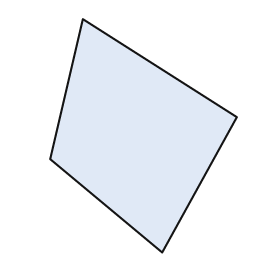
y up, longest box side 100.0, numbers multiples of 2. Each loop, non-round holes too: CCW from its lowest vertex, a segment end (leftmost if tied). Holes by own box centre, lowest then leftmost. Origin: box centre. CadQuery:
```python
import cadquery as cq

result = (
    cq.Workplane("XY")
    .moveTo(8.0, -50.0)
    .lineTo(40.0, 8.0)
    .lineTo(-26.0, 50.0)
    .lineTo(-40.0, -10.0)
    .close()
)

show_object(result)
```